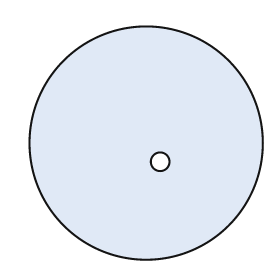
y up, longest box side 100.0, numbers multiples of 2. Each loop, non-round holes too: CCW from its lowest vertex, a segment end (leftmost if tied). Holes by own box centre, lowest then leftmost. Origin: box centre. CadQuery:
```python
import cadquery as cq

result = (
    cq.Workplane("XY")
    .moveTo(0.0, 0.0)
    .circle(50.0)
    .moveTo(6.0, -8.0)
    .circle(4.0)
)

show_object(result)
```